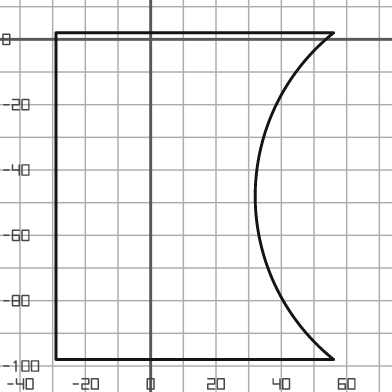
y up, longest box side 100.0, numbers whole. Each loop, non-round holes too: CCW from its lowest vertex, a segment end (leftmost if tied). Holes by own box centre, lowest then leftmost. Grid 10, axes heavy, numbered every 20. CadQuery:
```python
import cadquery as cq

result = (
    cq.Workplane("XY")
    .moveTo(-29.0, -98.0)
    .lineTo(56.0, -98.0)
    .threePointArc((32.0, -48.0), (56.0, 2.0))
    .lineTo(-29.0, 2.0)
    .close()
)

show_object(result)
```